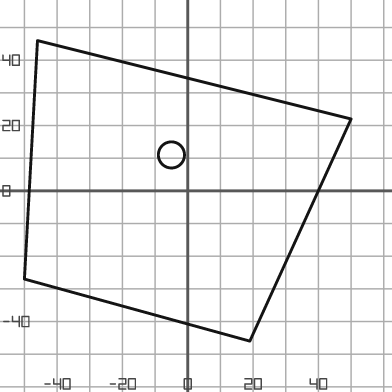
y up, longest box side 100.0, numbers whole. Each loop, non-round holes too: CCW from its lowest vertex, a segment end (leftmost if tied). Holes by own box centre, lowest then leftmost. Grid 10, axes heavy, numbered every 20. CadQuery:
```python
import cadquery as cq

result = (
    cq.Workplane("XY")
    .moveTo(19.0, -46.0)
    .lineTo(50.0, 22.0)
    .lineTo(-46.0, 46.0)
    .lineTo(-50.0, -27.0)
    .close()
    .moveTo(-5.0, 11.0)
    .circle(4.0)
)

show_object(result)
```